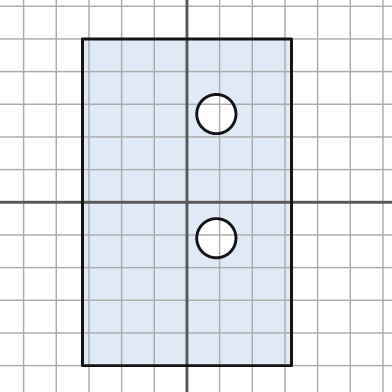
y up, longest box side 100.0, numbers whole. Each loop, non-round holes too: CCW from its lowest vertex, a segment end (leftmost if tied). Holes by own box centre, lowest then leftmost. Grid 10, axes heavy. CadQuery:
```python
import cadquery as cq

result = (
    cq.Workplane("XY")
    .moveTo(-32.0, -50.0)
    .lineTo(32.0, -50.0)
    .lineTo(32.0, 50.0)
    .lineTo(-32.0, 50.0)
    .close()
    .moveTo(9.0, -11.0)
    .circle(6.0)
    .moveTo(9.0, 27.0)
    .circle(6.0)
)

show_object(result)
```